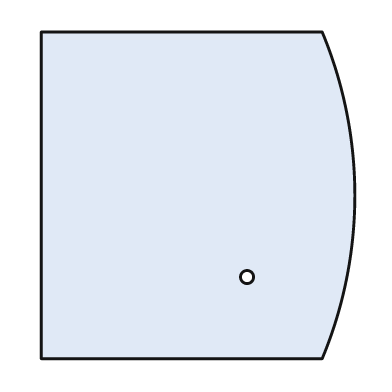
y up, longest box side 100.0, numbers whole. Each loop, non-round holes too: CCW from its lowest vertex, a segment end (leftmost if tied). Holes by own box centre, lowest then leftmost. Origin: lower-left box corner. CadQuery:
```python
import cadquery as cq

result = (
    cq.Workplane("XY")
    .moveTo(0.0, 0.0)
    .lineTo(86.0, 0.0)
    .threePointArc((96.0, 50.0), (86.0, 100.0))
    .lineTo(0.0, 100.0)
    .close()
    .moveTo(63.0, 25.0)
    .circle(2.0)
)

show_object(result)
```